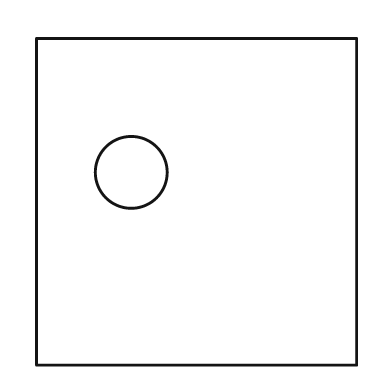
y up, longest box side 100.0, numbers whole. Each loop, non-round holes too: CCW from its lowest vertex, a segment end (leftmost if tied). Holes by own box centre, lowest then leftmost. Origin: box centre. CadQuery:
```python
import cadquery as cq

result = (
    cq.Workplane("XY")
    .moveTo(-49.0, -50.0)
    .lineTo(49.0, -50.0)
    .lineTo(49.0, 50.0)
    .lineTo(-49.0, 50.0)
    .close()
    .moveTo(-20.0, 9.0)
    .circle(11.0)
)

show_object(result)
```